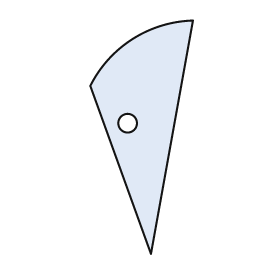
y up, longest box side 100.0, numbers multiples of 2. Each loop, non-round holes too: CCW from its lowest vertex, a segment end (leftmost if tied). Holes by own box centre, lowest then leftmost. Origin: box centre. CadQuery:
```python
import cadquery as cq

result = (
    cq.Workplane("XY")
    .moveTo(4.0, -50.0)
    .lineTo(22.0, 50.0)
    .threePointArc((-4.0, 42.0), (-22.0, 22.0))
    .close()
    .moveTo(-6.0, 6.0)
    .circle(4.0)
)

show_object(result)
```